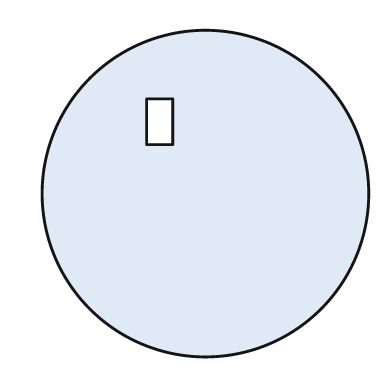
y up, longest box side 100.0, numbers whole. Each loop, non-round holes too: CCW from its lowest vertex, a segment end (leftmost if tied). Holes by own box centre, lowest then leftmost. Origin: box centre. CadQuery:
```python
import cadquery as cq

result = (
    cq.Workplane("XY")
    .moveTo(0.0, 0.0)
    .circle(50.0)
    .moveTo(-18.0, 15.0)
    .lineTo(-10.0, 15.0)
    .lineTo(-10.0, 29.0)
    .lineTo(-18.0, 29.0)
    .close()
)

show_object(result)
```